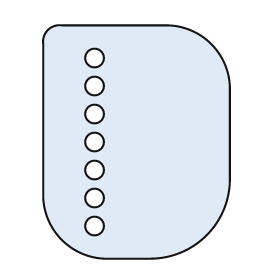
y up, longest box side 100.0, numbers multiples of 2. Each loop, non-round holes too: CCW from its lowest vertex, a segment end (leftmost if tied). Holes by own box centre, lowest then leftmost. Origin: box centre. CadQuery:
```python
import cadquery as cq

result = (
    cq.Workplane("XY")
    .moveTo(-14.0, -50.0)
    .lineTo(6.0, -50.0)
    .threePointArc((30.0, -40.0), (40.0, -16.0))
    .lineTo(40.0, 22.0)
    .threePointArc((32.0, 42.0), (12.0, 50.0))
    .lineTo(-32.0, 50.0)
    .threePointArc((-38.0, 48.0), (-40.0, 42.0))
    .lineTo(-40.0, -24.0)
    .threePointArc((-32.0, -42.0), (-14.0, -50.0))
    .close()
    .moveTo(-18.0, -36.0)
    .circle(4.0)
    .moveTo(-18.0, -24.0)
    .circle(4.0)
    .moveTo(-18.0, -12.0)
    .circle(4.0)
    .moveTo(-18.0, 0.0)
    .circle(4.0)
    .moveTo(-18.0, 12.0)
    .circle(4.0)
    .moveTo(-18.0, 24.0)
    .circle(4.0)
    .moveTo(-18.0, 36.0)
    .circle(4.0)
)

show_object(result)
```